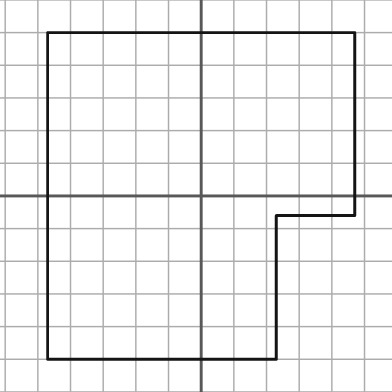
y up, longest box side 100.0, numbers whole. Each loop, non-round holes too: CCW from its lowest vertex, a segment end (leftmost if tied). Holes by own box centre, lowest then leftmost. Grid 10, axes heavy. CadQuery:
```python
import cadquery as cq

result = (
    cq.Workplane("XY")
    .moveTo(-47.0, -50.0)
    .lineTo(23.0, -50.0)
    .lineTo(23.0, -6.0)
    .lineTo(47.0, -6.0)
    .lineTo(47.0, 50.0)
    .lineTo(-47.0, 50.0)
    .close()
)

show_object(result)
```